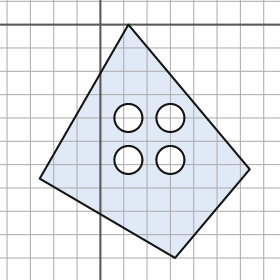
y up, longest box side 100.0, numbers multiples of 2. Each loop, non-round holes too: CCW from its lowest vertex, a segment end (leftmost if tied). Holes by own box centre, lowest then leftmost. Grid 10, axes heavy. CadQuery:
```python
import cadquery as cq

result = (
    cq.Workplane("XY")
    .moveTo(32.0, -100.0)
    .lineTo(64.0, -62.0)
    .lineTo(12.0, 0.0)
    .lineTo(-26.0, -66.0)
    .close()
    .moveTo(12.0, -58.0)
    .circle(6.0)
    .moveTo(30.0, -58.0)
    .circle(6.0)
    .moveTo(12.0, -40.0)
    .circle(6.0)
    .moveTo(30.0, -40.0)
    .circle(6.0)
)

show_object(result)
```